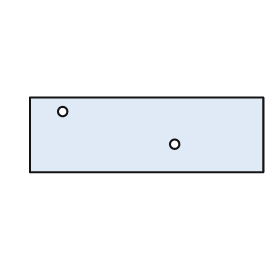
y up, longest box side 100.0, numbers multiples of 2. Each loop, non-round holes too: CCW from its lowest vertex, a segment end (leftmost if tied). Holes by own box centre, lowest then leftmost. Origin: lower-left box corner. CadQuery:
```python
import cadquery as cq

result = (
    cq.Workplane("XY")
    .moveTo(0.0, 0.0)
    .lineTo(100.0, 0.0)
    .lineTo(100.0, 32.0)
    .lineTo(0.0, 32.0)
    .close()
    .moveTo(62.0, 12.0)
    .circle(2.0)
    .moveTo(14.0, 26.0)
    .circle(2.0)
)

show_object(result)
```